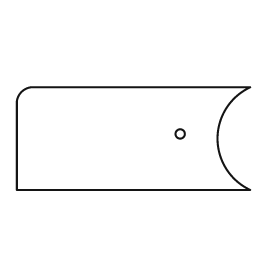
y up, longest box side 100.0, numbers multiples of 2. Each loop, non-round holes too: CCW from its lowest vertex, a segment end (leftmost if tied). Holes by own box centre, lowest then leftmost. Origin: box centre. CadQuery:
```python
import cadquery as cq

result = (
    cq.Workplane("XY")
    .moveTo(-50.0, -22.0)
    .lineTo(50.0, -22.0)
    .threePointArc((36.0, 0.0), (50.0, 22.0))
    .lineTo(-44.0, 22.0)
    .threePointArc((-48.0, 20.0), (-50.0, 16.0))
    .close()
    .moveTo(20.0, 2.0)
    .circle(2.0)
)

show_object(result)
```